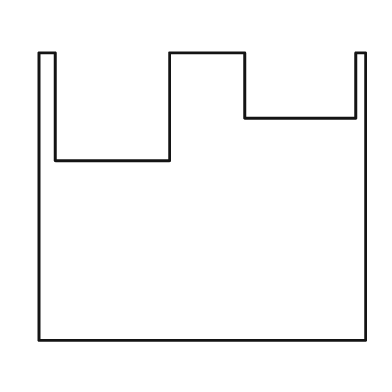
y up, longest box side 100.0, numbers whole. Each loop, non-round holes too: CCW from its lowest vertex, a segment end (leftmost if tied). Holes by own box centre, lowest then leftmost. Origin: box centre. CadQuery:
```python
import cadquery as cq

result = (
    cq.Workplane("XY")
    .moveTo(-50.0, -44.0)
    .lineTo(50.0, -44.0)
    .lineTo(50.0, 44.0)
    .lineTo(47.0, 44.0)
    .lineTo(47.0, 24.0)
    .lineTo(13.0, 24.0)
    .lineTo(13.0, 44.0)
    .lineTo(-10.0, 44.0)
    .lineTo(-10.0, 11.0)
    .lineTo(-45.0, 11.0)
    .lineTo(-45.0, 44.0)
    .lineTo(-50.0, 44.0)
    .close()
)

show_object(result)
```